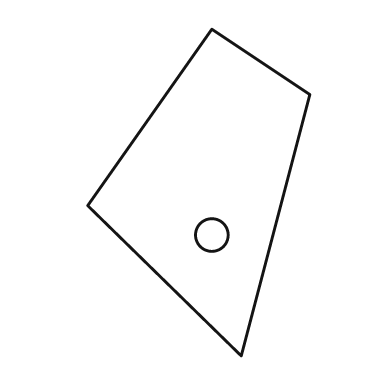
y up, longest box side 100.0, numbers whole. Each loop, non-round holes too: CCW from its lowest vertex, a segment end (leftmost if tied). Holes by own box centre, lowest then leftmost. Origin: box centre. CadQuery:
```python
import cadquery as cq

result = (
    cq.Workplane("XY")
    .moveTo(13.0, -50.0)
    .lineTo(34.0, 30.0)
    .lineTo(4.0, 50.0)
    .lineTo(-34.0, -4.0)
    .close()
    .moveTo(4.0, -13.0)
    .circle(5.0)
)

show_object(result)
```